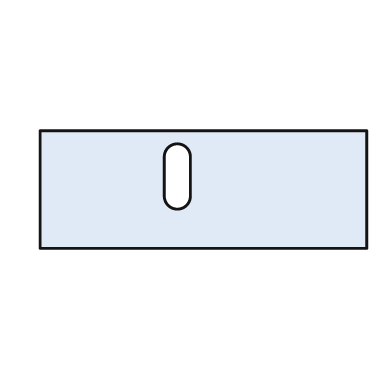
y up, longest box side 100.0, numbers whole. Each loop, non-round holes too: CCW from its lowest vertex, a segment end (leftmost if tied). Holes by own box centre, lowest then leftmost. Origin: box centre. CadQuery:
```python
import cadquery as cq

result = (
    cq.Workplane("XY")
    .moveTo(-50.0, -18.0)
    .lineTo(50.0, -18.0)
    .lineTo(50.0, 18.0)
    .lineTo(-50.0, 18.0)
    .close()
    .moveTo(-12.0, -2.0)
    .threePointArc((-8.0, -6.0), (-4.0, -2.0))
    .lineTo(-4.0, 10.0)
    .threePointArc((-8.0, 14.0), (-12.0, 10.0))
    .close()
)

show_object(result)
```